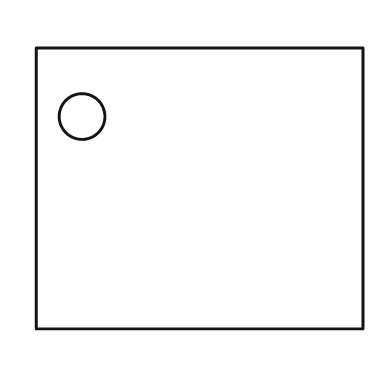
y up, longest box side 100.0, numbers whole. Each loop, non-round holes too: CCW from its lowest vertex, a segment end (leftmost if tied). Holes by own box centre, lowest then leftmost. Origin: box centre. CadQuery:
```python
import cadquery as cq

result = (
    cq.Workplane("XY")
    .moveTo(-50.0, -43.0)
    .lineTo(50.0, -43.0)
    .lineTo(50.0, 43.0)
    .lineTo(-50.0, 43.0)
    .close()
    .moveTo(-36.0, 22.0)
    .circle(7.0)
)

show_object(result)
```